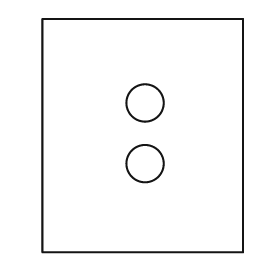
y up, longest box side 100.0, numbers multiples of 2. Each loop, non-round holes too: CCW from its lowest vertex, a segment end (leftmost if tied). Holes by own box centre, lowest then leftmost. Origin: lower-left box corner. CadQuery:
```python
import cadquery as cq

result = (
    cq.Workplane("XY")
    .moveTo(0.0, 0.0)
    .lineTo(86.0, 0.0)
    .lineTo(86.0, 100.0)
    .lineTo(0.0, 100.0)
    .close()
    .moveTo(44.0, 38.0)
    .circle(8.0)
    .moveTo(44.0, 64.0)
    .circle(8.0)
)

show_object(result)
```